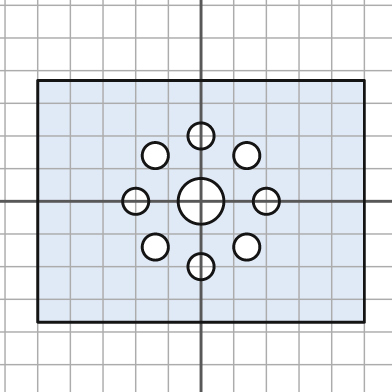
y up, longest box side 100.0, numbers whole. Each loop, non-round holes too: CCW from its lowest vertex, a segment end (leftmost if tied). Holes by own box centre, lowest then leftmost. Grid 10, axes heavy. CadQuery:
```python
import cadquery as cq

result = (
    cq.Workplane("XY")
    .moveTo(-50.0, -37.0)
    .lineTo(50.0, -37.0)
    .lineTo(50.0, 37.0)
    .lineTo(-50.0, 37.0)
    .close()
    .moveTo(0.0, -20.0)
    .circle(4.0)
    .moveTo(-14.0, -14.0)
    .circle(4.0)
    .moveTo(14.0, -14.0)
    .circle(4.0)
    .moveTo(-20.0, 0.0)
    .circle(4.0)
    .moveTo(0.0, 0.0)
    .circle(7.0)
    .moveTo(20.0, 0.0)
    .circle(4.0)
    .moveTo(-14.0, 14.0)
    .circle(4.0)
    .moveTo(14.0, 14.0)
    .circle(4.0)
    .moveTo(0.0, 20.0)
    .circle(4.0)
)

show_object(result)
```